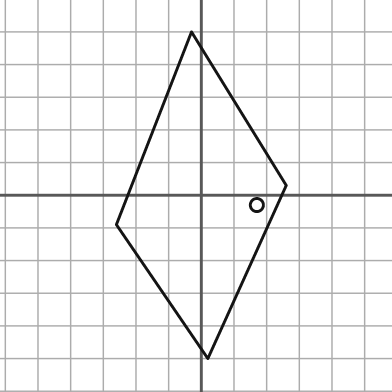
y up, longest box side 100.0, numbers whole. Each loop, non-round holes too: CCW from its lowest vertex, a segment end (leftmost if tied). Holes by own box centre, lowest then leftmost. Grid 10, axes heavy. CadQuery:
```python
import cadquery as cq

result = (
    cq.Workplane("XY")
    .moveTo(2.0, -50.0)
    .lineTo(26.0, 3.0)
    .lineTo(-3.0, 50.0)
    .lineTo(-26.0, -9.0)
    .close()
    .moveTo(17.0, -3.0)
    .circle(2.0)
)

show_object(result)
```